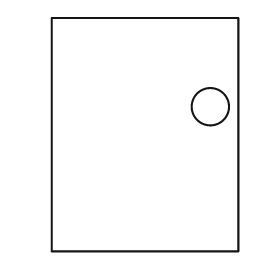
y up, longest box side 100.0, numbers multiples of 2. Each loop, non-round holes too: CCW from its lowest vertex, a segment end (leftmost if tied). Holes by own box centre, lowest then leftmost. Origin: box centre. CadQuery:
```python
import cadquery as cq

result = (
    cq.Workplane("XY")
    .moveTo(-40.0, -50.0)
    .lineTo(40.0, -50.0)
    .lineTo(40.0, 50.0)
    .lineTo(-40.0, 50.0)
    .close()
    .moveTo(28.0, 12.0)
    .circle(8.0)
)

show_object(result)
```